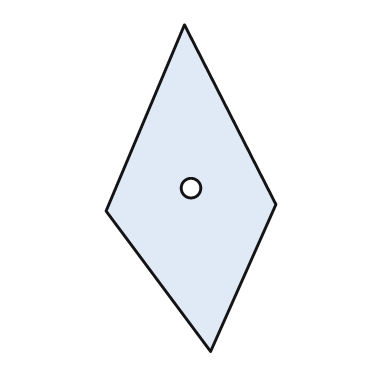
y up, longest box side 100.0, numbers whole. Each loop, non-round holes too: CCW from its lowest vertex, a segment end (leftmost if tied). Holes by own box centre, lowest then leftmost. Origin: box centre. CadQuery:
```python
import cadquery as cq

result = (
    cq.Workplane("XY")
    .moveTo(6.0, -50.0)
    .lineTo(26.0, -5.0)
    .lineTo(-2.0, 50.0)
    .lineTo(-26.0, -7.0)
    .close()
    .moveTo(0.0, 0.0)
    .circle(3.0)
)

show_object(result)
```